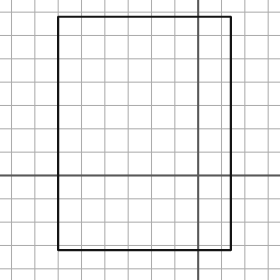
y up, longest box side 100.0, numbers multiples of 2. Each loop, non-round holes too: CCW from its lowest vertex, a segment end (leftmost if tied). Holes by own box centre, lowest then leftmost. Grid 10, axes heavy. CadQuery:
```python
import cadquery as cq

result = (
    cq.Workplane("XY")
    .moveTo(-60.0, -32.0)
    .lineTo(14.0, -32.0)
    .lineTo(14.0, 68.0)
    .lineTo(-60.0, 68.0)
    .close()
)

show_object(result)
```